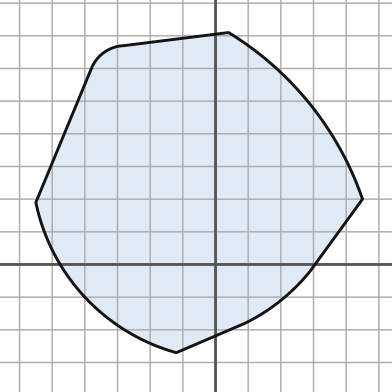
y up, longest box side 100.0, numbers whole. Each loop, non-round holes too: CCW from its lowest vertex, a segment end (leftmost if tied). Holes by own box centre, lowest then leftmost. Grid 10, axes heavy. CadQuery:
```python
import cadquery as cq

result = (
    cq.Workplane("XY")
    .moveTo(-12.0, -27.0)
    .lineTo(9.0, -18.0)
    .threePointArc((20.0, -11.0), (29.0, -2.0))
    .lineTo(45.0, 20.0)
    .threePointArc((29.0, 49.0), (4.0, 71.0))
    .lineTo(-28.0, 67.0)
    .threePointArc((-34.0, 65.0), (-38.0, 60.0))
    .lineTo(-55.0, 19.0)
    .threePointArc((-40.0, -10.0), (-12.0, -27.0))
    .close()
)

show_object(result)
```